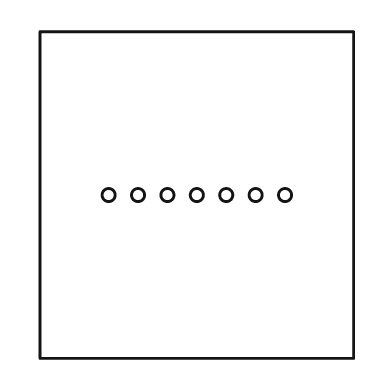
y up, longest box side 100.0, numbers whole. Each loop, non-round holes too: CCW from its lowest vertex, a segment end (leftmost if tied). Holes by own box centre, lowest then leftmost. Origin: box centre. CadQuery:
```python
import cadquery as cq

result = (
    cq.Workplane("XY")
    .moveTo(-48.0, -50.0)
    .lineTo(48.0, -50.0)
    .lineTo(48.0, 50.0)
    .lineTo(-48.0, 50.0)
    .close()
    .moveTo(-27.0, 0.0)
    .circle(2.0)
    .moveTo(-18.0, 0.0)
    .circle(2.0)
    .moveTo(-9.0, 0.0)
    .circle(2.0)
    .moveTo(0.0, 0.0)
    .circle(2.0)
    .moveTo(9.0, 0.0)
    .circle(2.0)
    .moveTo(18.0, 0.0)
    .circle(2.0)
    .moveTo(27.0, 0.0)
    .circle(2.0)
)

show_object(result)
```